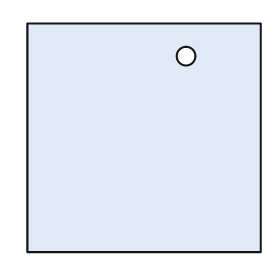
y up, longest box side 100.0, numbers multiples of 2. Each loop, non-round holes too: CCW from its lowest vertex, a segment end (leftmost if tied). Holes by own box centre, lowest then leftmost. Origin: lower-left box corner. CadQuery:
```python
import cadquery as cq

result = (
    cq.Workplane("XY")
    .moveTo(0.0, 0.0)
    .lineTo(100.0, 0.0)
    .lineTo(100.0, 98.0)
    .lineTo(0.0, 98.0)
    .close()
    .moveTo(68.0, 84.0)
    .circle(4.0)
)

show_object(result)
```